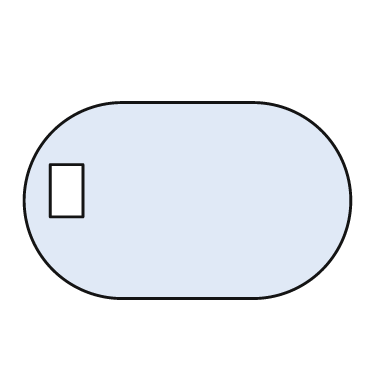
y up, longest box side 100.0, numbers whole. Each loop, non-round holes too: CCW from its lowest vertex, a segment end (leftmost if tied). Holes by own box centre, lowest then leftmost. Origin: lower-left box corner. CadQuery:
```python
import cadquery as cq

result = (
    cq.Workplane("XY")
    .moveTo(30.0, 0.0)
    .lineTo(70.0, 0.0)
    .threePointArc((100.0, 30.0), (70.0, 60.0))
    .lineTo(30.0, 60.0)
    .threePointArc((0.0, 30.0), (30.0, 0.0))
    .close()
    .moveTo(8.0, 25.0)
    .lineTo(18.0, 25.0)
    .lineTo(18.0, 41.0)
    .lineTo(8.0, 41.0)
    .close()
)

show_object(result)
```